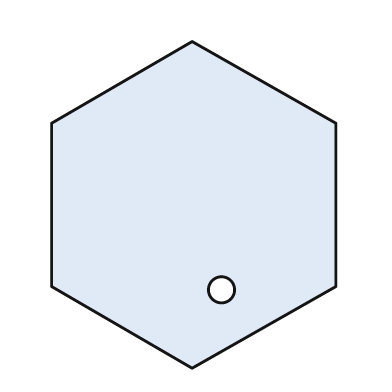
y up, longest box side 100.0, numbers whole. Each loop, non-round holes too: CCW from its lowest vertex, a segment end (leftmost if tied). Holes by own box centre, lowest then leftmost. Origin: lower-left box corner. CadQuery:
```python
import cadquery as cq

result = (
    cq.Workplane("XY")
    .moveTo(43.0, 0.0)
    .lineTo(87.0, 25.0)
    .lineTo(87.0, 75.0)
    .lineTo(43.0, 100.0)
    .lineTo(0.0, 75.0)
    .lineTo(0.0, 25.0)
    .close()
    .moveTo(52.0, 24.0)
    .circle(4.0)
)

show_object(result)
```